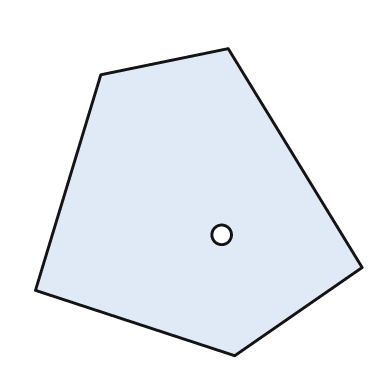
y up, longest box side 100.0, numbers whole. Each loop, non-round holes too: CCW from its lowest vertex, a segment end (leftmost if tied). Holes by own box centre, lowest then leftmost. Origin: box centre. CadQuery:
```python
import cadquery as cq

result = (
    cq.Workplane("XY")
    .moveTo(11.0, -47.0)
    .lineTo(50.0, -20.0)
    .lineTo(9.0, 47.0)
    .lineTo(-30.0, 39.0)
    .lineTo(-50.0, -27.0)
    .close()
    .moveTo(7.0, -10.0)
    .circle(3.0)
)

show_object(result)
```